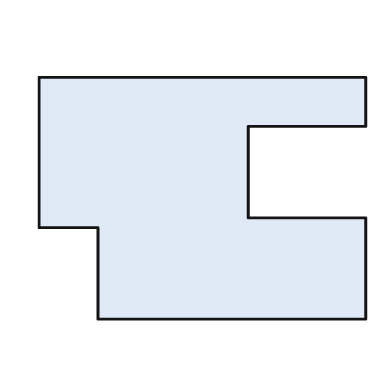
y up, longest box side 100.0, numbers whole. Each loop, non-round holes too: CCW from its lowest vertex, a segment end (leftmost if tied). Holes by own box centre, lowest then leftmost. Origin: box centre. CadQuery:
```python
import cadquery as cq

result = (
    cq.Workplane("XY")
    .moveTo(-32.0, -37.0)
    .lineTo(50.0, -37.0)
    .lineTo(50.0, -6.0)
    .lineTo(14.0, -6.0)
    .lineTo(14.0, 22.0)
    .lineTo(50.0, 22.0)
    .lineTo(50.0, 37.0)
    .lineTo(-50.0, 37.0)
    .lineTo(-50.0, -9.0)
    .lineTo(-32.0, -9.0)
    .close()
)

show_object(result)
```